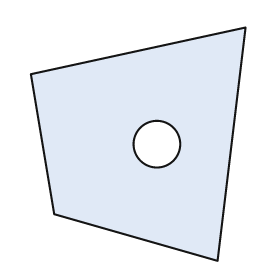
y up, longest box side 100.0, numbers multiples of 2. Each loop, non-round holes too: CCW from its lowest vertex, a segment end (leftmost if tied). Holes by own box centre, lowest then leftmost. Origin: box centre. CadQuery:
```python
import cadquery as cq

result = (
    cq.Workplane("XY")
    .moveTo(34.0, -50.0)
    .lineTo(46.0, 50.0)
    .lineTo(-46.0, 30.0)
    .lineTo(-36.0, -30.0)
    .close()
    .moveTo(8.0, 0.0)
    .circle(10.0)
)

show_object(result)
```